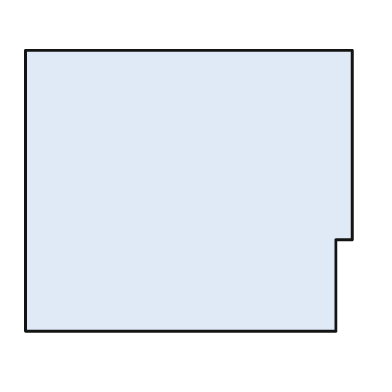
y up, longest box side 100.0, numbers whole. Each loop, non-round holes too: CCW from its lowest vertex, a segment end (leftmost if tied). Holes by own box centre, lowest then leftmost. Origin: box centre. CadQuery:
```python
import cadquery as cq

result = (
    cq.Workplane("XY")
    .moveTo(-50.0, -43.0)
    .lineTo(45.0, -43.0)
    .lineTo(45.0, -15.0)
    .lineTo(50.0, -15.0)
    .lineTo(50.0, 43.0)
    .lineTo(-50.0, 43.0)
    .close()
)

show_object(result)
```